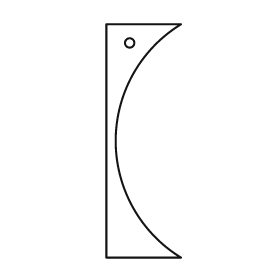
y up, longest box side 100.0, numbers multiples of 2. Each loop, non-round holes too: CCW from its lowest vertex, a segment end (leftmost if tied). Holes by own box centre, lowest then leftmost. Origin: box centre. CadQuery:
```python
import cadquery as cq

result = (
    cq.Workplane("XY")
    .moveTo(-16.0, -50.0)
    .lineTo(16.0, -50.0)
    .threePointArc((-12.0, 0.0), (16.0, 50.0))
    .lineTo(-16.0, 50.0)
    .close()
    .moveTo(-6.0, 42.0)
    .circle(2.0)
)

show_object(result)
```